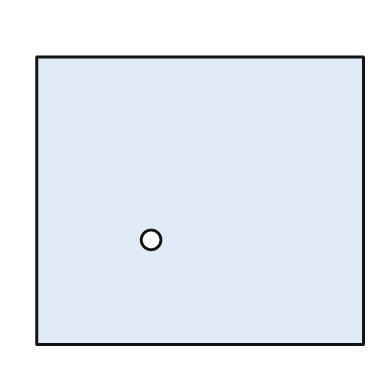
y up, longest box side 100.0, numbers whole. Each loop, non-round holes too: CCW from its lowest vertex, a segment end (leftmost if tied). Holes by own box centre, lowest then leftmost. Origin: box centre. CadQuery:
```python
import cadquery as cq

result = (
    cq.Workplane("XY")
    .moveTo(-50.0, -44.0)
    .lineTo(50.0, -44.0)
    .lineTo(50.0, 44.0)
    .lineTo(-50.0, 44.0)
    .close()
    .moveTo(-15.0, -12.0)
    .circle(3.0)
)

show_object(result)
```